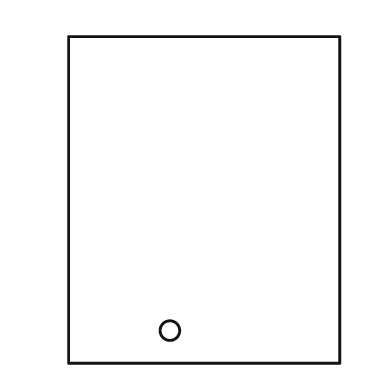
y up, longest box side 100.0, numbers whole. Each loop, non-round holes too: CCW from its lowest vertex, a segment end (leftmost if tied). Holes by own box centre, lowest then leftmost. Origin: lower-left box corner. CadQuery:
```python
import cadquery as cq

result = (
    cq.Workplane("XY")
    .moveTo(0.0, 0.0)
    .lineTo(83.0, 0.0)
    .lineTo(83.0, 100.0)
    .lineTo(0.0, 100.0)
    .close()
    .moveTo(31.0, 10.0)
    .circle(3.0)
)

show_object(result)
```